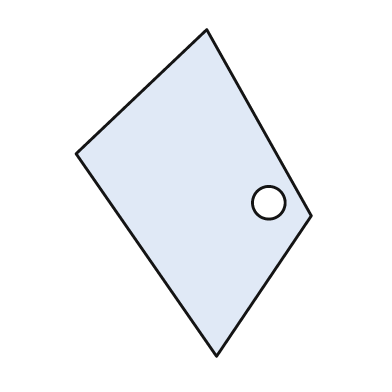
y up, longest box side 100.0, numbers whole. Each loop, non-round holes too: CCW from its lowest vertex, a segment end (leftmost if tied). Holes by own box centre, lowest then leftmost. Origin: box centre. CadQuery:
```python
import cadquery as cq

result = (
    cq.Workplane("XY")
    .moveTo(7.0, -50.0)
    .lineTo(36.0, -7.0)
    .lineTo(4.0, 50.0)
    .lineTo(-36.0, 12.0)
    .close()
    .moveTo(23.0, -3.0)
    .circle(5.0)
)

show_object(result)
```